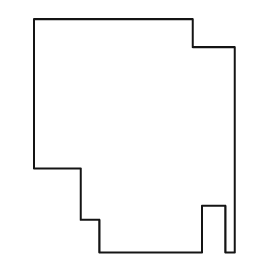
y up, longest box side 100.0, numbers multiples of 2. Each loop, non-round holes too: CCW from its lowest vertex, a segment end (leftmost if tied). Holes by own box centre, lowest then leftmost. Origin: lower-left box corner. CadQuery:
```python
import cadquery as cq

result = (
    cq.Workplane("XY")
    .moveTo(28.0, 0.0)
    .lineTo(72.0, 0.0)
    .lineTo(72.0, 20.0)
    .lineTo(82.0, 20.0)
    .lineTo(82.0, 0.0)
    .lineTo(86.0, 0.0)
    .lineTo(86.0, 88.0)
    .lineTo(68.0, 88.0)
    .lineTo(68.0, 100.0)
    .lineTo(0.0, 100.0)
    .lineTo(0.0, 36.0)
    .lineTo(20.0, 36.0)
    .lineTo(20.0, 14.0)
    .lineTo(28.0, 14.0)
    .close()
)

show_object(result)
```